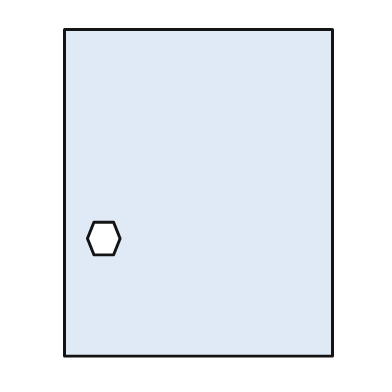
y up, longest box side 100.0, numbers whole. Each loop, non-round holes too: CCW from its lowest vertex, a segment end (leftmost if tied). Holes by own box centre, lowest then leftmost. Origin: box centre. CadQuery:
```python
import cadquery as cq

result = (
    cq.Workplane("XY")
    .moveTo(-41.0, -50.0)
    .lineTo(41.0, -50.0)
    .lineTo(41.0, 50.0)
    .lineTo(-41.0, 50.0)
    .close()
    .moveTo(-32.0, -19.0)
    .lineTo(-26.0, -19.0)
    .lineTo(-24.0, -14.0)
    .lineTo(-26.0, -9.0)
    .lineTo(-32.0, -9.0)
    .lineTo(-34.0, -14.0)
    .close()
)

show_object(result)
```